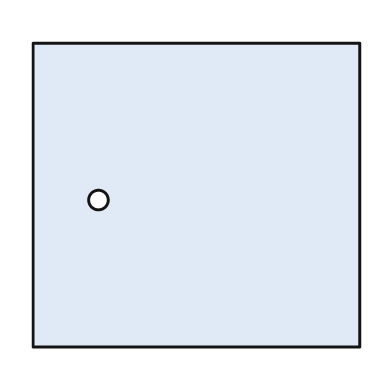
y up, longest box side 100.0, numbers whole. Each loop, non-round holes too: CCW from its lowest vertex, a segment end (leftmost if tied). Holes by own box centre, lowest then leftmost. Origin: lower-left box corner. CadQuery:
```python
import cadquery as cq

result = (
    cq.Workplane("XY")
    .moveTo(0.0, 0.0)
    .lineTo(100.0, 0.0)
    .lineTo(100.0, 93.0)
    .lineTo(0.0, 93.0)
    .close()
    .moveTo(20.0, 45.0)
    .circle(3.0)
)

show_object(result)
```